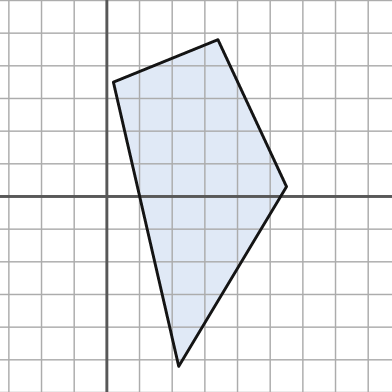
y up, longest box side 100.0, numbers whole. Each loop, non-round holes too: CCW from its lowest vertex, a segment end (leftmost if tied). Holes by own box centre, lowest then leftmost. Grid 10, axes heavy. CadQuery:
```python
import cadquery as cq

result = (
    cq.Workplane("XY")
    .moveTo(22.0, -52.0)
    .lineTo(55.0, 3.0)
    .lineTo(34.0, 48.0)
    .lineTo(2.0, 35.0)
    .close()
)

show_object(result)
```